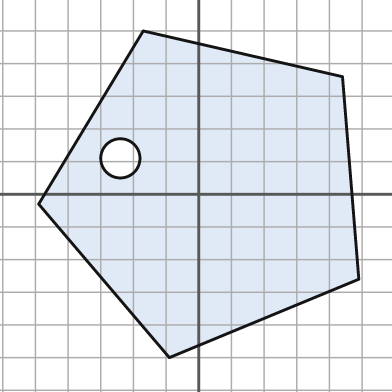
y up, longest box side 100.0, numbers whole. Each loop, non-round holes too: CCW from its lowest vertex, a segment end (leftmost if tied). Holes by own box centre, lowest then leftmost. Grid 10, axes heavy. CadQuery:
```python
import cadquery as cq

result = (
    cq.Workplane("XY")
    .moveTo(-9.0, -50.0)
    .lineTo(49.0, -26.0)
    .lineTo(44.0, 36.0)
    .lineTo(-17.0, 50.0)
    .lineTo(-49.0, -3.0)
    .close()
    .moveTo(-24.0, 11.0)
    .circle(6.0)
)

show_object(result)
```